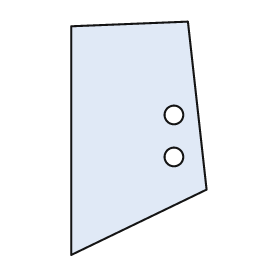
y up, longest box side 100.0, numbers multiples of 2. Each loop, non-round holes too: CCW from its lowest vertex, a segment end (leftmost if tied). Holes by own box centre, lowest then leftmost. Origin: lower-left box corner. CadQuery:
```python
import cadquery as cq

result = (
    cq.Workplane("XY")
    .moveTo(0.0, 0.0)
    .lineTo(58.0, 28.0)
    .lineTo(50.0, 100.0)
    .lineTo(0.0, 98.0)
    .close()
    .moveTo(44.0, 42.0)
    .circle(4.0)
    .moveTo(44.0, 60.0)
    .circle(4.0)
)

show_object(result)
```